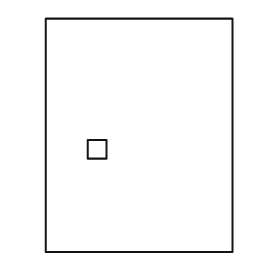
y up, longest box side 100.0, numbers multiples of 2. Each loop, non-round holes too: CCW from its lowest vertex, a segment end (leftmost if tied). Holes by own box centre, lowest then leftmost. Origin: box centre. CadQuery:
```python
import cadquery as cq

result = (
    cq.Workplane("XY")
    .moveTo(-40.0, -50.0)
    .lineTo(40.0, -50.0)
    .lineTo(40.0, 50.0)
    .lineTo(-40.0, 50.0)
    .close()
    .moveTo(-22.0, -10.0)
    .lineTo(-14.0, -10.0)
    .lineTo(-14.0, -2.0)
    .lineTo(-22.0, -2.0)
    .close()
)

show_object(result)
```